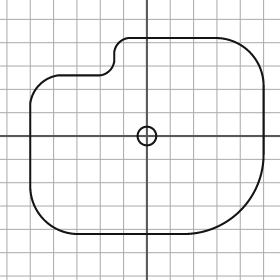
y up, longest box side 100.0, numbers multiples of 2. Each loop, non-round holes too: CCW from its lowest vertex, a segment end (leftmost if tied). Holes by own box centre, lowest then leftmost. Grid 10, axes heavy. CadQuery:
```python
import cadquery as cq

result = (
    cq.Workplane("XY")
    .moveTo(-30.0, -42.0)
    .lineTo(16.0, -42.0)
    .threePointArc((40.0, -32.0), (50.0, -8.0))
    .lineTo(50.0, 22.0)
    .threePointArc((44.0, 36.0), (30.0, 42.0))
    .lineTo(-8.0, 42.0)
    .threePointArc((-12.0, 40.0), (-14.0, 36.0))
    .lineTo(-14.0, 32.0)
    .threePointArc((-16.0, 28.0), (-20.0, 26.0))
    .lineTo(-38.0, 26.0)
    .threePointArc((-46.0, 22.0), (-50.0, 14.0))
    .lineTo(-50.0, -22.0)
    .threePointArc((-44.0, -36.0), (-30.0, -42.0))
    .close()
    .moveTo(0.0, 0.0)
    .circle(4.0)
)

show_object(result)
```